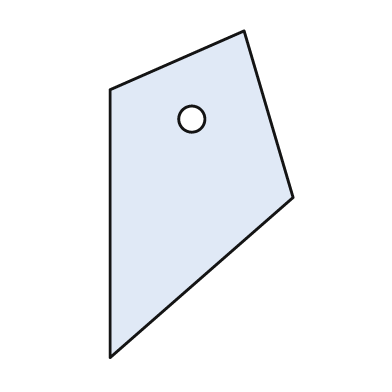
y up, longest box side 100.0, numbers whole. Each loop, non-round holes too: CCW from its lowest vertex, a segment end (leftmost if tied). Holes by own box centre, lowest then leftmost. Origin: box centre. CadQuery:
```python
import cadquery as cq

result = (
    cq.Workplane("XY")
    .moveTo(-28.0, -50.0)
    .lineTo(28.0, -1.0)
    .lineTo(13.0, 50.0)
    .lineTo(-28.0, 32.0)
    .close()
    .moveTo(-3.0, 23.0)
    .circle(4.0)
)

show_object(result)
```